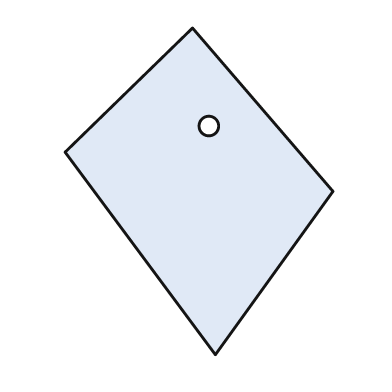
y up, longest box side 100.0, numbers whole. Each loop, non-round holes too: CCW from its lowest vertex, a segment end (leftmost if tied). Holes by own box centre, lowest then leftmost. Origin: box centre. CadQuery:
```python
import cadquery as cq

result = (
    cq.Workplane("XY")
    .moveTo(5.0, -50.0)
    .lineTo(41.0, 0.0)
    .lineTo(-2.0, 50.0)
    .lineTo(-41.0, 12.0)
    .close()
    .moveTo(3.0, 20.0)
    .circle(3.0)
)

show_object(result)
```